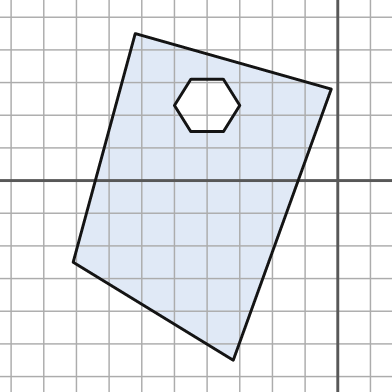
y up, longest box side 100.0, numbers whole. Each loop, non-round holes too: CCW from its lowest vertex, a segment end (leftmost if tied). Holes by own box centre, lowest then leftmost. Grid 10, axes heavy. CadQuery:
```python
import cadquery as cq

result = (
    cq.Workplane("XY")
    .moveTo(-32.0, -55.0)
    .lineTo(-2.0, 28.0)
    .lineTo(-62.0, 45.0)
    .lineTo(-81.0, -25.0)
    .close()
    .moveTo(-45.0, 15.0)
    .lineTo(-35.0, 15.0)
    .lineTo(-30.0, 23.0)
    .lineTo(-35.0, 31.0)
    .lineTo(-45.0, 31.0)
    .lineTo(-50.0, 23.0)
    .close()
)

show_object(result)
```